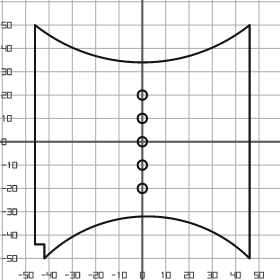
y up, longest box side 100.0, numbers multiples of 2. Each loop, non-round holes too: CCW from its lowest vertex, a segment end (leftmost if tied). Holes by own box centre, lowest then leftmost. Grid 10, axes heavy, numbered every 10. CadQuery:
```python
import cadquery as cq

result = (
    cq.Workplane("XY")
    .moveTo(-42.0, -50.0)
    .threePointArc((2.0, -32.0), (46.0, -50.0))
    .lineTo(46.0, 50.0)
    .threePointArc((0.0, 34.0), (-46.0, 50.0))
    .lineTo(-46.0, -44.0)
    .lineTo(-42.0, -44.0)
    .close()
    .moveTo(0.0, -20.0)
    .circle(2.0)
    .moveTo(0.0, -10.0)
    .circle(2.0)
    .moveTo(0.0, 0.0)
    .circle(2.0)
    .moveTo(0.0, 10.0)
    .circle(2.0)
    .moveTo(0.0, 20.0)
    .circle(2.0)
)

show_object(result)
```